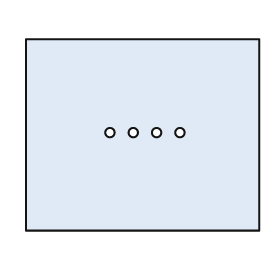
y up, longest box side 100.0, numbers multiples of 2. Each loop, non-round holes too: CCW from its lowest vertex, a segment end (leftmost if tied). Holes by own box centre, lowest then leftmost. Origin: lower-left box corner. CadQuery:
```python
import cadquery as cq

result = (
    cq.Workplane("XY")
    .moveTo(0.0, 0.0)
    .lineTo(100.0, 0.0)
    .lineTo(100.0, 82.0)
    .lineTo(0.0, 82.0)
    .close()
    .moveTo(36.0, 42.0)
    .circle(2.0)
    .moveTo(46.0, 42.0)
    .circle(2.0)
    .moveTo(56.0, 42.0)
    .circle(2.0)
    .moveTo(66.0, 42.0)
    .circle(2.0)
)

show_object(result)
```